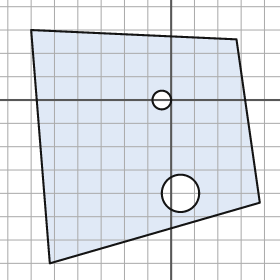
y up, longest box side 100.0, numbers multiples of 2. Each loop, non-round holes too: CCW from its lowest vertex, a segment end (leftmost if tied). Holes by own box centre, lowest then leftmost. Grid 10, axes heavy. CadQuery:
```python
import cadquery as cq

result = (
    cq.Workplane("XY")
    .moveTo(-52.0, -70.0)
    .lineTo(38.0, -44.0)
    .lineTo(28.0, 26.0)
    .lineTo(-60.0, 30.0)
    .close()
    .moveTo(4.0, -40.0)
    .circle(8.0)
    .moveTo(-4.0, 0.0)
    .circle(4.0)
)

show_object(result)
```